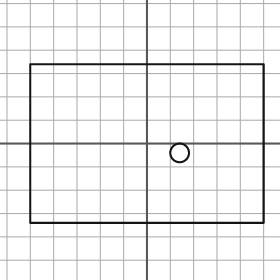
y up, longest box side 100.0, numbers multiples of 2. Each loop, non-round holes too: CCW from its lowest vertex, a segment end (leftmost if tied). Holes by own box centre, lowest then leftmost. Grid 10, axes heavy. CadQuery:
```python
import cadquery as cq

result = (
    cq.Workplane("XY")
    .moveTo(-50.0, -34.0)
    .lineTo(50.0, -34.0)
    .lineTo(50.0, 34.0)
    .lineTo(-50.0, 34.0)
    .close()
    .moveTo(14.0, -4.0)
    .circle(4.0)
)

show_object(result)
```